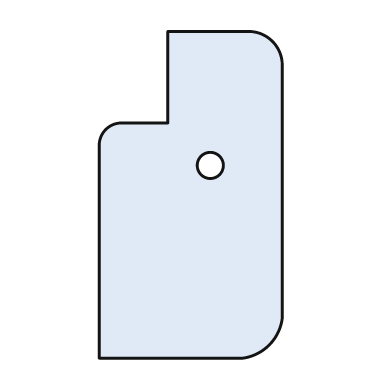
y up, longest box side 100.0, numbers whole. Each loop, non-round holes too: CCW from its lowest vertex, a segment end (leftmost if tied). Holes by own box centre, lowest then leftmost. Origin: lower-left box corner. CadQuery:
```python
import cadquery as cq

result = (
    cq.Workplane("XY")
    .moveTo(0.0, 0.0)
    .lineTo(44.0, 0.0)
    .threePointArc((52.0, 4.0), (56.0, 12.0))
    .lineTo(56.0, 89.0)
    .threePointArc((53.0, 97.0), (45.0, 100.0))
    .lineTo(21.0, 100.0)
    .lineTo(21.0, 72.0)
    .lineTo(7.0, 72.0)
    .threePointArc((2.0, 70.0), (0.0, 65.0))
    .close()
    .moveTo(34.0, 59.0)
    .circle(4.0)
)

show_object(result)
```